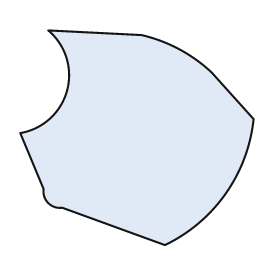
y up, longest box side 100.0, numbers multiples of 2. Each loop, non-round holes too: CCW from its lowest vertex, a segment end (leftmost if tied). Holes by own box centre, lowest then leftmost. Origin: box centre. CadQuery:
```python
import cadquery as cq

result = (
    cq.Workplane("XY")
    .moveTo(12.0, -46.0)
    .threePointArc((38.0, -24.0), (50.0, 8.0))
    .lineTo(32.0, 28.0)
    .threePointArc((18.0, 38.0), (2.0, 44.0))
    .lineTo(-38.0, 46.0)
    .threePointArc((-30.0, 20.0), (-50.0, 2.0))
    .lineTo(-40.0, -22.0)
    .threePointArc((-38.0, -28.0), (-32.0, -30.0))
    .close()
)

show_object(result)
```